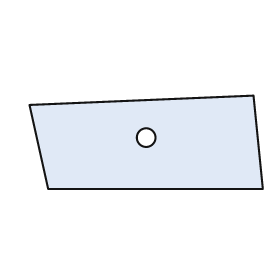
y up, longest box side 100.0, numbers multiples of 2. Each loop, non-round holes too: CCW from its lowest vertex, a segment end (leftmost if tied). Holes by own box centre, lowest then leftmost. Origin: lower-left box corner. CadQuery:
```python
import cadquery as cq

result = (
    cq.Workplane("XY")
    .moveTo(8.0, 0.0)
    .lineTo(100.0, 0.0)
    .lineTo(96.0, 40.0)
    .lineTo(0.0, 36.0)
    .close()
    .moveTo(50.0, 22.0)
    .circle(4.0)
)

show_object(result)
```